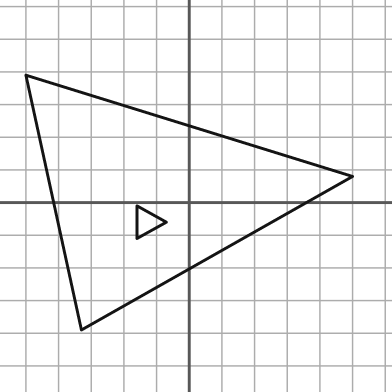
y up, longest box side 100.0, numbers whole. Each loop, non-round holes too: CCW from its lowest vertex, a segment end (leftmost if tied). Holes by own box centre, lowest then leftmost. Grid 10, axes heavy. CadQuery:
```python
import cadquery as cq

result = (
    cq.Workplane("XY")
    .moveTo(-33.0, -39.0)
    .lineTo(50.0, 8.0)
    .lineTo(-50.0, 39.0)
    .close()
    .moveTo(-16.0, -11.0)
    .lineTo(-7.0, -6.0)
    .lineTo(-16.0, -1.0)
    .close()
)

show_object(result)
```